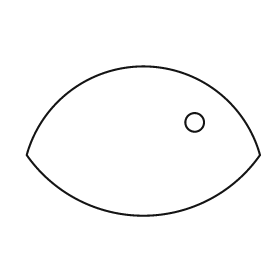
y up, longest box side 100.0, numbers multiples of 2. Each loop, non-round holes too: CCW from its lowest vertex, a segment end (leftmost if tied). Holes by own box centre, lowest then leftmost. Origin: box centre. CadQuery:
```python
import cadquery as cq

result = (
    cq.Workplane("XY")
    .moveTo(-50.0, -6.0)
    .threePointArc((0.0, -32.0), (50.0, -6.0))
    .threePointArc((0.0, 32.0), (-50.0, -6.0))
    .close()
    .moveTo(22.0, 8.0)
    .circle(4.0)
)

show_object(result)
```